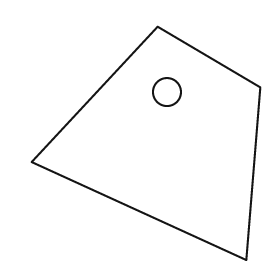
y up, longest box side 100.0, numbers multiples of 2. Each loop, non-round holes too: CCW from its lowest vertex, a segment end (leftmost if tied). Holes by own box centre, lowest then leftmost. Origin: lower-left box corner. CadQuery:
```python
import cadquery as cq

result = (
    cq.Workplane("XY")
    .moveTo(92.0, 0.0)
    .lineTo(98.0, 74.0)
    .lineTo(54.0, 100.0)
    .lineTo(0.0, 42.0)
    .close()
    .moveTo(58.0, 72.0)
    .circle(6.0)
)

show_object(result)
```